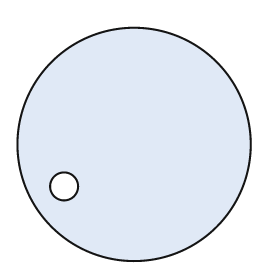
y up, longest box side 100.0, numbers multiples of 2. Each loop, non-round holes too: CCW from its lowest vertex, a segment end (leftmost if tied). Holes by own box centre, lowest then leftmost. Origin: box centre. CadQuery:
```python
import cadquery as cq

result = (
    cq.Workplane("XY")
    .moveTo(0.0, 0.0)
    .circle(50.0)
    .moveTo(-30.0, -18.0)
    .circle(6.0)
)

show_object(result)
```